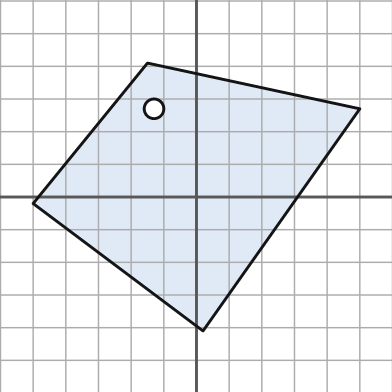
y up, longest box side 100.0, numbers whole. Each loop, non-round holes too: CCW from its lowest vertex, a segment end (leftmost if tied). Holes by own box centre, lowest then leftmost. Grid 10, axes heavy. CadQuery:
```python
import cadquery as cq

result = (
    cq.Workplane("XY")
    .moveTo(2.0, -41.0)
    .lineTo(50.0, 27.0)
    .lineTo(-15.0, 41.0)
    .lineTo(-50.0, -2.0)
    .close()
    .moveTo(-13.0, 27.0)
    .circle(3.0)
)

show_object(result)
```